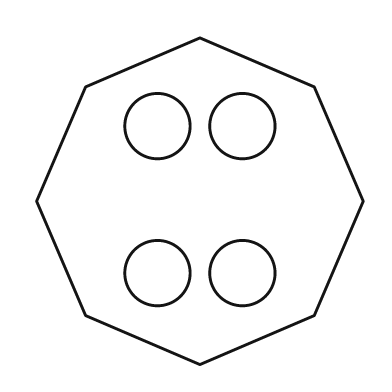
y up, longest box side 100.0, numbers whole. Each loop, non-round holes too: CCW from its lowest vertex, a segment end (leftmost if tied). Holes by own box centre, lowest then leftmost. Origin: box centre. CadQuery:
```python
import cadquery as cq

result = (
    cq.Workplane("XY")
    .moveTo(0.0, -50.0)
    .lineTo(35.0, -35.0)
    .lineTo(50.0, 0.0)
    .lineTo(35.0, 35.0)
    .lineTo(0.0, 50.0)
    .lineTo(-35.0, 35.0)
    .lineTo(-50.0, 0.0)
    .lineTo(-35.0, -35.0)
    .close()
    .moveTo(-13.0, -22.0)
    .circle(10.0)
    .moveTo(13.0, -22.0)
    .circle(10.0)
    .moveTo(-13.0, 23.0)
    .circle(10.0)
    .moveTo(13.0, 23.0)
    .circle(10.0)
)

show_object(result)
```